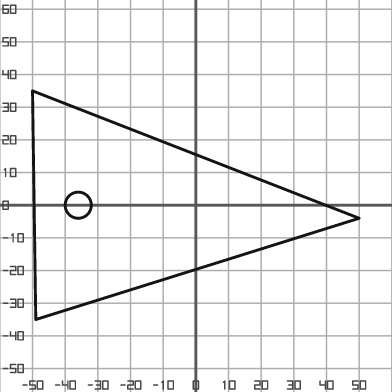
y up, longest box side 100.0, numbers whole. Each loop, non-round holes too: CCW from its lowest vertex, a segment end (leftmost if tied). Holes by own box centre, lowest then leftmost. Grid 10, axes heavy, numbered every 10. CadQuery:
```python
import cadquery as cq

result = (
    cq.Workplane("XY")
    .moveTo(-49.0, -35.0)
    .lineTo(50.0, -4.0)
    .lineTo(-50.0, 35.0)
    .close()
    .moveTo(-36.0, 0.0)
    .circle(4.0)
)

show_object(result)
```